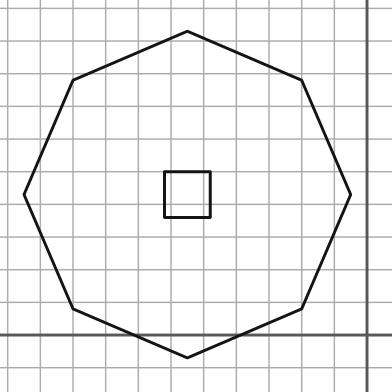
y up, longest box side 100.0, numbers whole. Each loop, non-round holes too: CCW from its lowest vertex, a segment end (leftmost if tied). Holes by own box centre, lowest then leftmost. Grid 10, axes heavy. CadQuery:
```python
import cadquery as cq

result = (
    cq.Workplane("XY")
    .moveTo(-55.0, -7.0)
    .lineTo(-20.0, 8.0)
    .lineTo(-5.0, 43.0)
    .lineTo(-20.0, 78.0)
    .lineTo(-55.0, 93.0)
    .lineTo(-90.0, 78.0)
    .lineTo(-105.0, 43.0)
    .lineTo(-90.0, 8.0)
    .close()
    .moveTo(-62.0, 36.0)
    .lineTo(-48.0, 36.0)
    .lineTo(-48.0, 50.0)
    .lineTo(-62.0, 50.0)
    .close()
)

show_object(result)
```